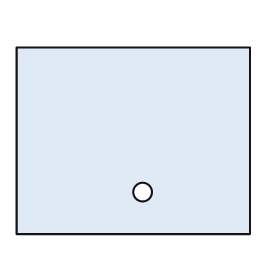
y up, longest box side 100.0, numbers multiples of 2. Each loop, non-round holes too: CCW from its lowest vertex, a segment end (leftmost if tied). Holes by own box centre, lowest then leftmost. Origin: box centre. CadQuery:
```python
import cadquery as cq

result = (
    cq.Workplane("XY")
    .moveTo(-50.0, -40.0)
    .lineTo(50.0, -40.0)
    .lineTo(50.0, 40.0)
    .lineTo(-50.0, 40.0)
    .close()
    .moveTo(4.0, -22.0)
    .circle(4.0)
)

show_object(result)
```